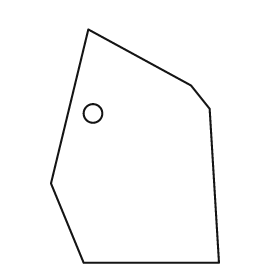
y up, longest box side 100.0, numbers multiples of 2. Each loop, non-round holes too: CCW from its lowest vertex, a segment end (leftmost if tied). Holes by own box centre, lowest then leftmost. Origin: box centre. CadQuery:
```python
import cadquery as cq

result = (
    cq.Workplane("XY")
    .moveTo(-22.0, -50.0)
    .lineTo(36.0, -50.0)
    .lineTo(32.0, 16.0)
    .lineTo(24.0, 26.0)
    .lineTo(-20.0, 50.0)
    .lineTo(-36.0, -16.0)
    .close()
    .moveTo(-18.0, 14.0)
    .circle(4.0)
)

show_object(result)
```